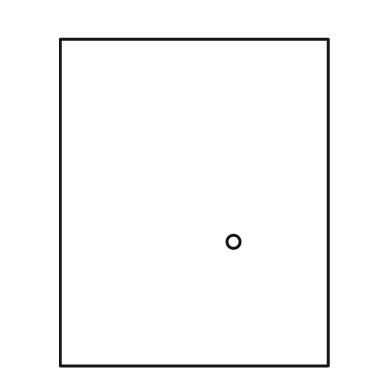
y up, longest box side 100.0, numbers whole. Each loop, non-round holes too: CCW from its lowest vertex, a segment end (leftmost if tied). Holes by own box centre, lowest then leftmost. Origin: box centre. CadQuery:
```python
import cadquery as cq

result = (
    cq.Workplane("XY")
    .moveTo(-41.0, -50.0)
    .lineTo(41.0, -50.0)
    .lineTo(41.0, 50.0)
    .lineTo(-41.0, 50.0)
    .close()
    .moveTo(12.0, -12.0)
    .circle(2.0)
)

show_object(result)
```